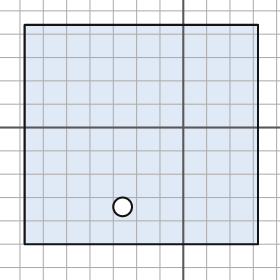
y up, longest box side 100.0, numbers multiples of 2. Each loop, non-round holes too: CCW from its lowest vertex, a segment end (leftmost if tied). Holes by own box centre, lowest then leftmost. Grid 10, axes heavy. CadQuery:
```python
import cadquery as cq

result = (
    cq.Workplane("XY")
    .moveTo(-68.0, -50.0)
    .lineTo(32.0, -50.0)
    .lineTo(32.0, 44.0)
    .lineTo(-68.0, 44.0)
    .close()
    .moveTo(-26.0, -34.0)
    .circle(4.0)
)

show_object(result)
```